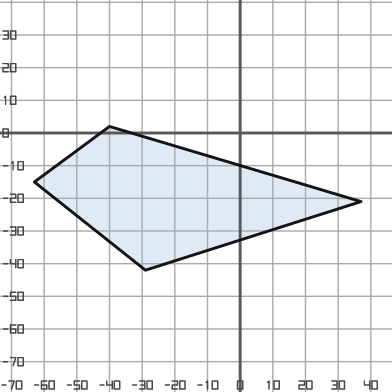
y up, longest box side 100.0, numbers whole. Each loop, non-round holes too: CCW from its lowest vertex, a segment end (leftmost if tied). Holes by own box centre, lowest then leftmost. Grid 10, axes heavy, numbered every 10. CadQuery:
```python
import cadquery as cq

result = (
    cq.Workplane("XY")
    .moveTo(-29.0, -42.0)
    .lineTo(37.0, -21.0)
    .lineTo(-40.0, 2.0)
    .lineTo(-63.0, -15.0)
    .close()
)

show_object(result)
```